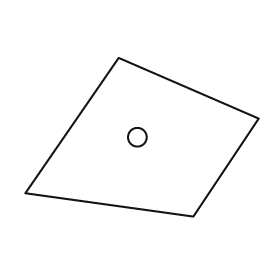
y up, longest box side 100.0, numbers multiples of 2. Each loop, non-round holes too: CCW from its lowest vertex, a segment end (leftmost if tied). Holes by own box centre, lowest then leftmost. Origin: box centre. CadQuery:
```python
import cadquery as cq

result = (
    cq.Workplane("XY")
    .moveTo(22.0, -34.0)
    .lineTo(50.0, 8.0)
    .lineTo(-10.0, 34.0)
    .lineTo(-50.0, -24.0)
    .close()
    .moveTo(-2.0, 0.0)
    .circle(4.0)
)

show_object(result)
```